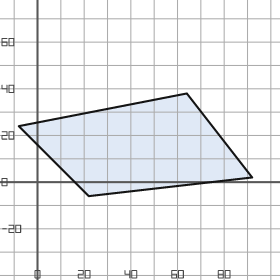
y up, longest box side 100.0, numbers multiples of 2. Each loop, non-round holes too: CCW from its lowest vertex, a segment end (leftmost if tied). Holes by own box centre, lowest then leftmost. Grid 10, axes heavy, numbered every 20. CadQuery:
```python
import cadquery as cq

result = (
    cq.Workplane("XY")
    .moveTo(22.0, -6.0)
    .lineTo(92.0, 2.0)
    .lineTo(64.0, 38.0)
    .lineTo(-8.0, 24.0)
    .close()
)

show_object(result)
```